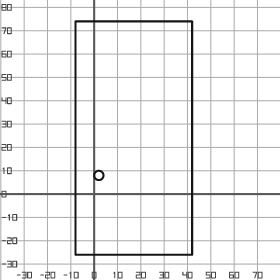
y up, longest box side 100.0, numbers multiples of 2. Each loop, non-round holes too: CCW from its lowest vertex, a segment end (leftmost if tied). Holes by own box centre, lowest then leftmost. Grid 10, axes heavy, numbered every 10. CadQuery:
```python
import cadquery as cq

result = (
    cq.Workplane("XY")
    .moveTo(-8.0, -26.0)
    .lineTo(42.0, -26.0)
    .lineTo(42.0, 74.0)
    .lineTo(-8.0, 74.0)
    .close()
    .moveTo(2.0, 8.0)
    .circle(2.0)
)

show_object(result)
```